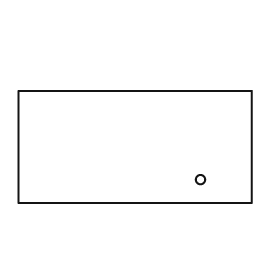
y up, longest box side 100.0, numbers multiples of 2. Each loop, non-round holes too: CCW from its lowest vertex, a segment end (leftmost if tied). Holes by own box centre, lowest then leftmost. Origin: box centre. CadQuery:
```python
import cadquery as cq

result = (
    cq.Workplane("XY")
    .moveTo(-50.0, -24.0)
    .lineTo(50.0, -24.0)
    .lineTo(50.0, 24.0)
    .lineTo(-50.0, 24.0)
    .close()
    .moveTo(28.0, -14.0)
    .circle(2.0)
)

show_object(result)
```